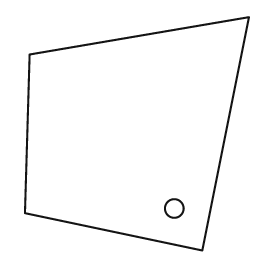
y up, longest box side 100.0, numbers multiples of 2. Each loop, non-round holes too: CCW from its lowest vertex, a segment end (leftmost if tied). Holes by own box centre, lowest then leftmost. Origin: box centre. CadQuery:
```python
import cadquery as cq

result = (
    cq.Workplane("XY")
    .moveTo(28.0, -50.0)
    .lineTo(48.0, 50.0)
    .lineTo(-46.0, 34.0)
    .lineTo(-48.0, -34.0)
    .close()
    .moveTo(16.0, -32.0)
    .circle(4.0)
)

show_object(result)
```